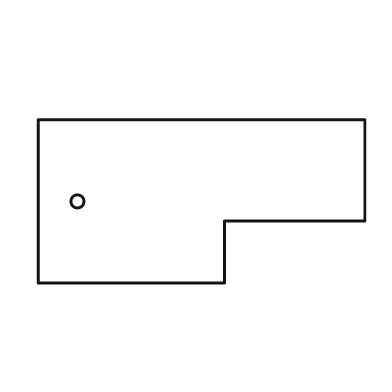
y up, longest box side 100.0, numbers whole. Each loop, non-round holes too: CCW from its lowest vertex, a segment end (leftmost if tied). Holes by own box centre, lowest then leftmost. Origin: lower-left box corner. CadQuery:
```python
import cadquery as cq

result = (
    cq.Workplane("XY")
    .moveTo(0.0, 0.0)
    .lineTo(57.0, 0.0)
    .lineTo(57.0, 19.0)
    .lineTo(100.0, 19.0)
    .lineTo(100.0, 50.0)
    .lineTo(0.0, 50.0)
    .close()
    .moveTo(12.0, 25.0)
    .circle(2.0)
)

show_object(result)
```